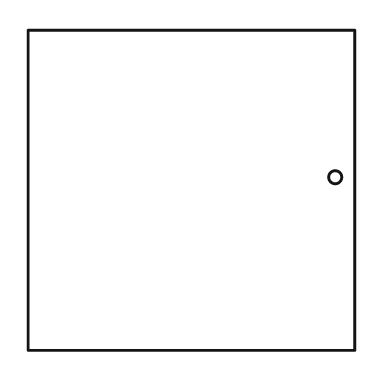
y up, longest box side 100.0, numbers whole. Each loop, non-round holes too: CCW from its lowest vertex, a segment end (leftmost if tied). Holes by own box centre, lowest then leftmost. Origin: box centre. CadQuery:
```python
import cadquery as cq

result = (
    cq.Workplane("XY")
    .moveTo(-50.0, -49.0)
    .lineTo(50.0, -49.0)
    .lineTo(50.0, 49.0)
    .lineTo(-50.0, 49.0)
    .close()
    .moveTo(44.0, 4.0)
    .circle(2.0)
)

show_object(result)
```